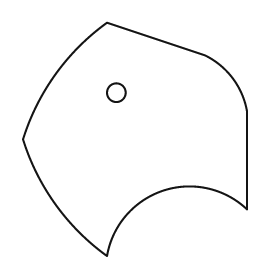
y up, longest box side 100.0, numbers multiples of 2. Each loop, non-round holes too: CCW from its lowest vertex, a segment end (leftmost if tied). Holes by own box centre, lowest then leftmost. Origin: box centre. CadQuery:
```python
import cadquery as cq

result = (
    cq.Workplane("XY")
    .moveTo(-12.0, -50.0)
    .threePointArc((12.0, -22.0), (48.0, -30.0))
    .lineTo(48.0, 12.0)
    .threePointArc((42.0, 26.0), (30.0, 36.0))
    .lineTo(-12.0, 50.0)
    .threePointArc((-34.0, 28.0), (-48.0, 0.0))
    .threePointArc((-34.0, -28.0), (-12.0, -50.0))
    .close()
    .moveTo(-8.0, 20.0)
    .circle(4.0)
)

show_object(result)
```